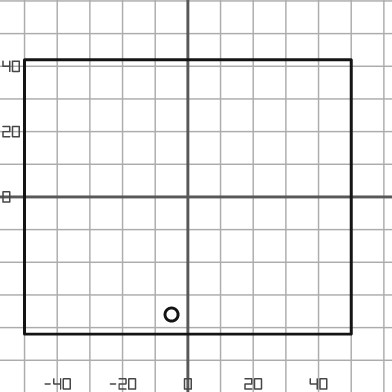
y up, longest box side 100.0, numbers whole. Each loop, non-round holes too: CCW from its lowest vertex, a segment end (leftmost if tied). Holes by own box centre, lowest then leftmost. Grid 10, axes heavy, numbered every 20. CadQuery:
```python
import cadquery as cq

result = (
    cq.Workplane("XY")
    .moveTo(-50.0, -42.0)
    .lineTo(50.0, -42.0)
    .lineTo(50.0, 42.0)
    .lineTo(-50.0, 42.0)
    .close()
    .moveTo(-5.0, -36.0)
    .circle(2.0)
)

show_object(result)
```